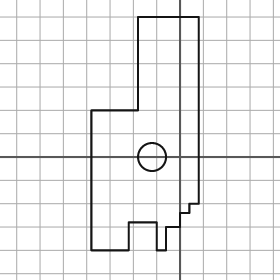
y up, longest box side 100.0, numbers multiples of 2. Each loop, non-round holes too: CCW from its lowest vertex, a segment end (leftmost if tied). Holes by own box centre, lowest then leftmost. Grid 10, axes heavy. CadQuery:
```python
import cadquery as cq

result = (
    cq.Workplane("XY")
    .moveTo(-38.0, -40.0)
    .lineTo(-22.0, -40.0)
    .lineTo(-22.0, -28.0)
    .lineTo(-10.0, -28.0)
    .lineTo(-10.0, -40.0)
    .lineTo(-6.0, -40.0)
    .lineTo(-6.0, -30.0)
    .lineTo(0.0, -30.0)
    .lineTo(0.0, -24.0)
    .lineTo(4.0, -24.0)
    .lineTo(4.0, -20.0)
    .lineTo(8.0, -20.0)
    .lineTo(8.0, 60.0)
    .lineTo(-18.0, 60.0)
    .lineTo(-18.0, 20.0)
    .lineTo(-38.0, 20.0)
    .close()
    .moveTo(-12.0, 0.0)
    .circle(6.0)
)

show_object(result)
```